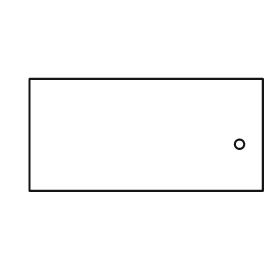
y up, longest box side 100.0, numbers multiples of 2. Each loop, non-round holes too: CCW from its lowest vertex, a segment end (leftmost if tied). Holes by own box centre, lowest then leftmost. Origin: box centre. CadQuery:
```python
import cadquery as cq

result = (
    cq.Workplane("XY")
    .moveTo(-50.0, -24.0)
    .lineTo(50.0, -24.0)
    .lineTo(50.0, 24.0)
    .lineTo(-50.0, 24.0)
    .close()
    .moveTo(40.0, -4.0)
    .circle(2.0)
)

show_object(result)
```